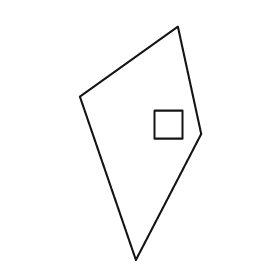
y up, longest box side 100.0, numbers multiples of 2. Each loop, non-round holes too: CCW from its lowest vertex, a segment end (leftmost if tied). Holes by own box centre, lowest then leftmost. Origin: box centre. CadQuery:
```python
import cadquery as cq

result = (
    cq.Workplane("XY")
    .moveTo(-2.0, -50.0)
    .lineTo(26.0, 4.0)
    .lineTo(16.0, 50.0)
    .lineTo(-26.0, 20.0)
    .close()
    .moveTo(6.0, 2.0)
    .lineTo(18.0, 2.0)
    .lineTo(18.0, 14.0)
    .lineTo(6.0, 14.0)
    .close()
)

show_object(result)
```